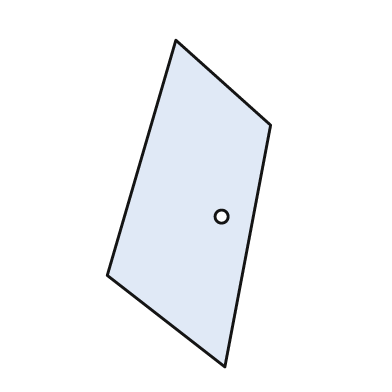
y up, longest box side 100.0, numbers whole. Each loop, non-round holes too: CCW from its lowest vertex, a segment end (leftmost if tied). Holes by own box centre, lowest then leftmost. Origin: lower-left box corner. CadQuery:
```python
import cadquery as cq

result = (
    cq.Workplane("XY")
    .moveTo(36.0, 0.0)
    .lineTo(50.0, 74.0)
    .lineTo(21.0, 100.0)
    .lineTo(0.0, 28.0)
    .close()
    .moveTo(35.0, 46.0)
    .circle(2.0)
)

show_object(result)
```